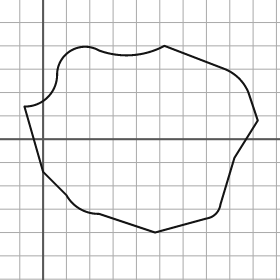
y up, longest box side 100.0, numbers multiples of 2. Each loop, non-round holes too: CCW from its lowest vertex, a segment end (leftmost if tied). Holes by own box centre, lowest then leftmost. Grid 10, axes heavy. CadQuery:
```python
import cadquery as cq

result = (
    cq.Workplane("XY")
    .moveTo(48.0, -40.0)
    .lineTo(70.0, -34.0)
    .threePointArc((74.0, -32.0), (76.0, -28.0))
    .lineTo(82.0, -8.0)
    .lineTo(92.0, 8.0)
    .lineTo(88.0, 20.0)
    .threePointArc((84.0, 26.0), (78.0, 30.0))
    .lineTo(52.0, 40.0)
    .threePointArc((38.0, 36.0), (24.0, 38.0))
    .threePointArc((12.0, 38.0), (6.0, 28.0))
    .threePointArc((2.0, 18.0), (-8.0, 14.0))
    .lineTo(0.0, -14.0)
    .lineTo(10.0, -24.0)
    .threePointArc((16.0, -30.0), (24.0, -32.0))
    .close()
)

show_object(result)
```